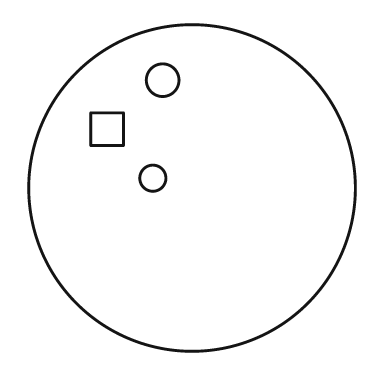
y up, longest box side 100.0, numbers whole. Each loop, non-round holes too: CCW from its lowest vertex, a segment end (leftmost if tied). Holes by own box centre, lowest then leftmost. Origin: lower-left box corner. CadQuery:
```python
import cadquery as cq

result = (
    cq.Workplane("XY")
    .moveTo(50.0, 50.0)
    .circle(50.0)
    .moveTo(38.0, 53.0)
    .circle(4.0)
    .moveTo(19.0, 63.0)
    .lineTo(29.0, 63.0)
    .lineTo(29.0, 73.0)
    .lineTo(19.0, 73.0)
    .close()
    .moveTo(41.0, 83.0)
    .circle(5.0)
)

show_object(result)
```